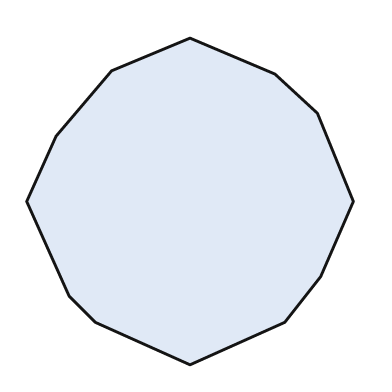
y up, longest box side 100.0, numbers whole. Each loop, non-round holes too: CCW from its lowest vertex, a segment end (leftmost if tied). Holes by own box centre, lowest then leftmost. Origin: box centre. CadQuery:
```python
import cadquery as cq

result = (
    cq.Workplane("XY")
    .moveTo(0.0, -50.0)
    .lineTo(29.0, -37.0)
    .lineTo(40.0, -23.0)
    .lineTo(50.0, 0.0)
    .lineTo(39.0, 27.0)
    .lineTo(26.0, 39.0)
    .lineTo(0.0, 50.0)
    .lineTo(-24.0, 40.0)
    .lineTo(-41.0, 20.0)
    .lineTo(-50.0, 0.0)
    .lineTo(-37.0, -29.0)
    .lineTo(-29.0, -37.0)
    .close()
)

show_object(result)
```